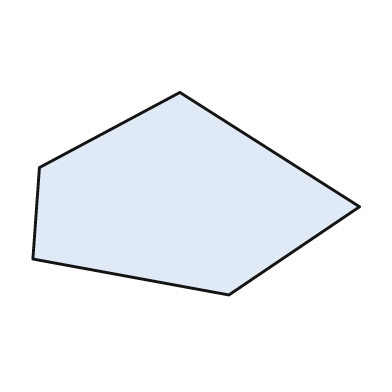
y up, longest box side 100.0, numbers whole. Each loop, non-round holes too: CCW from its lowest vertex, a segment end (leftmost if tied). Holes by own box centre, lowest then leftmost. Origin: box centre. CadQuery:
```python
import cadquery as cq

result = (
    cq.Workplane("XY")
    .moveTo(10.0, -31.0)
    .lineTo(50.0, -4.0)
    .lineTo(-5.0, 31.0)
    .lineTo(-48.0, 8.0)
    .lineTo(-50.0, -20.0)
    .close()
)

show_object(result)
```